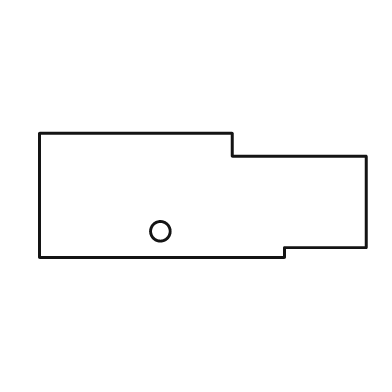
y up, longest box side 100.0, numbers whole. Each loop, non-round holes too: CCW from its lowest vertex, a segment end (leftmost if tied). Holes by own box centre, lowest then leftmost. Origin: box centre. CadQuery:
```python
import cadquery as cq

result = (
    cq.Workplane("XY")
    .moveTo(-50.0, -19.0)
    .lineTo(25.0, -19.0)
    .lineTo(25.0, -16.0)
    .lineTo(50.0, -16.0)
    .lineTo(50.0, 12.0)
    .lineTo(9.0, 12.0)
    .lineTo(9.0, 19.0)
    .lineTo(-50.0, 19.0)
    .close()
    .moveTo(-13.0, -11.0)
    .circle(3.0)
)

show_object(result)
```